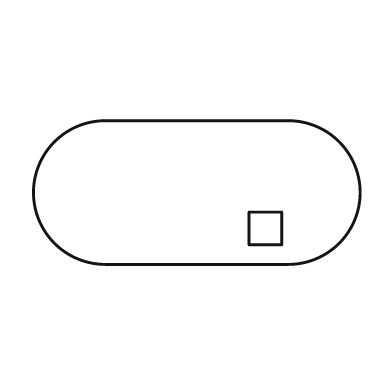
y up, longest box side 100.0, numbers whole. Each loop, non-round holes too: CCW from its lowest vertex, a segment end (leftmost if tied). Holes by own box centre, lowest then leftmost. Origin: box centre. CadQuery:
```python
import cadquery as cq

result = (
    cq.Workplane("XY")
    .moveTo(-28.0, -22.0)
    .lineTo(28.0, -22.0)
    .threePointArc((50.0, 0.0), (28.0, 22.0))
    .lineTo(-28.0, 22.0)
    .threePointArc((-50.0, 0.0), (-28.0, -22.0))
    .close()
    .moveTo(16.0, -16.0)
    .lineTo(26.0, -16.0)
    .lineTo(26.0, -6.0)
    .lineTo(16.0, -6.0)
    .close()
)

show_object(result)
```